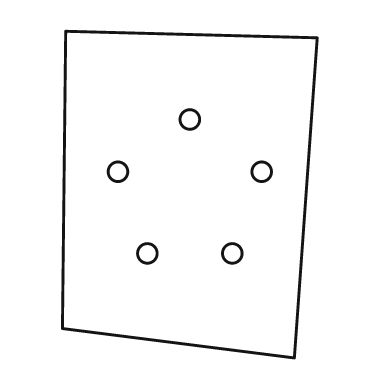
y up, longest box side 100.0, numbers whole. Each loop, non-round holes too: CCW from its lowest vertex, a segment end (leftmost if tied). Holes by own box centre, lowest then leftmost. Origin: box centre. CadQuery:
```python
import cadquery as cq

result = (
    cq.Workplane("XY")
    .moveTo(32.0, -50.0)
    .lineTo(39.0, 48.0)
    .lineTo(-38.0, 50.0)
    .lineTo(-39.0, -41.0)
    .close()
    .moveTo(-13.0, -18.0)
    .circle(3.0)
    .moveTo(13.0, -18.0)
    .circle(3.0)
    .moveTo(-22.0, 7.0)
    .circle(3.0)
    .moveTo(22.0, 7.0)
    .circle(3.0)
    .moveTo(0.0, 23.0)
    .circle(3.0)
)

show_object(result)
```